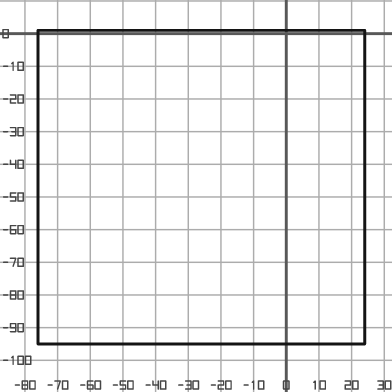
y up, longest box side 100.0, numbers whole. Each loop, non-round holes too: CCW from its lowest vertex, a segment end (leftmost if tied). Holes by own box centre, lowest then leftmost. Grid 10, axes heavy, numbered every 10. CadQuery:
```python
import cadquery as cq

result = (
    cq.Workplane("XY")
    .moveTo(-76.0, -95.0)
    .lineTo(24.0, -95.0)
    .lineTo(24.0, 1.0)
    .lineTo(-76.0, 1.0)
    .close()
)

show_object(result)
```